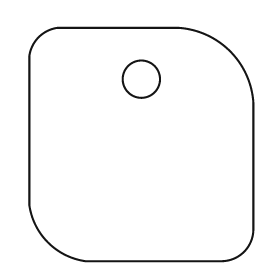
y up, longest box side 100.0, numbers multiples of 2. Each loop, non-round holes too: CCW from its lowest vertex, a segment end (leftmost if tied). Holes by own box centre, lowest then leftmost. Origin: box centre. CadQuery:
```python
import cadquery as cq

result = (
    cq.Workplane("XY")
    .moveTo(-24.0, -50.0)
    .lineTo(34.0, -50.0)
    .threePointArc((44.0, -46.0), (48.0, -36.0))
    .lineTo(48.0, 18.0)
    .threePointArc((38.0, 40.0), (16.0, 50.0))
    .lineTo(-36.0, 50.0)
    .threePointArc((-44.0, 46.0), (-48.0, 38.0))
    .lineTo(-48.0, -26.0)
    .threePointArc((-40.0, -42.0), (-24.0, -50.0))
    .close()
    .moveTo(0.0, 28.0)
    .circle(8.0)
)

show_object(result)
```